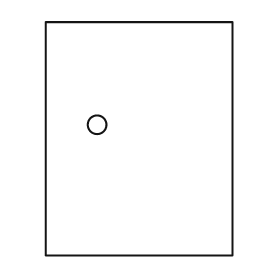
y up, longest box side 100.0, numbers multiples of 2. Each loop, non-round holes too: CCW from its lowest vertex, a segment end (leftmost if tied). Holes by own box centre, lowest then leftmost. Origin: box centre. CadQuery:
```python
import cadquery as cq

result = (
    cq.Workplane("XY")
    .moveTo(-40.0, -50.0)
    .lineTo(40.0, -50.0)
    .lineTo(40.0, 50.0)
    .lineTo(-40.0, 50.0)
    .close()
    .moveTo(-18.0, 6.0)
    .circle(4.0)
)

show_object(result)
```